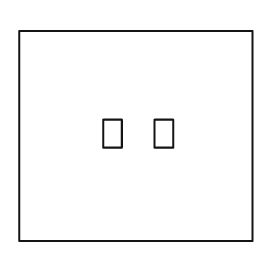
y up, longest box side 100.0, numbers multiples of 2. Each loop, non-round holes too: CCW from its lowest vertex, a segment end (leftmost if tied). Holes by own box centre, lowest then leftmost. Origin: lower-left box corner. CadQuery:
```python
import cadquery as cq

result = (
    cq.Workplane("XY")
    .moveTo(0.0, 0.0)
    .lineTo(100.0, 0.0)
    .lineTo(100.0, 90.0)
    .lineTo(0.0, 90.0)
    .close()
    .moveTo(36.0, 40.0)
    .lineTo(44.0, 40.0)
    .lineTo(44.0, 52.0)
    .lineTo(36.0, 52.0)
    .close()
    .moveTo(58.0, 40.0)
    .lineTo(66.0, 40.0)
    .lineTo(66.0, 52.0)
    .lineTo(58.0, 52.0)
    .close()
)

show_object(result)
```